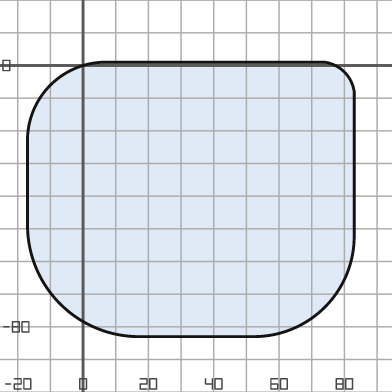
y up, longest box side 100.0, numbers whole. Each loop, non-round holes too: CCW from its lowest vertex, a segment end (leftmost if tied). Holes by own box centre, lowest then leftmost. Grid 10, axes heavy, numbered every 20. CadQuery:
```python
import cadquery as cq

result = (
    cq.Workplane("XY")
    .moveTo(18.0, -83.0)
    .lineTo(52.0, -83.0)
    .threePointArc((74.0, -74.0), (83.0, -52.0))
    .lineTo(83.0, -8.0)
    .threePointArc((80.0, -2.0), (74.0, 1.0))
    .lineTo(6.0, 1.0)
    .threePointArc((-10.0, -6.0), (-17.0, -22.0))
    .lineTo(-17.0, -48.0)
    .threePointArc((-7.0, -73.0), (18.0, -83.0))
    .close()
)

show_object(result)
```